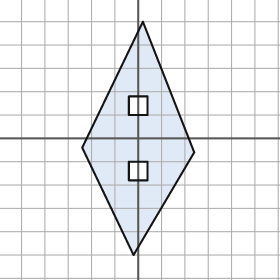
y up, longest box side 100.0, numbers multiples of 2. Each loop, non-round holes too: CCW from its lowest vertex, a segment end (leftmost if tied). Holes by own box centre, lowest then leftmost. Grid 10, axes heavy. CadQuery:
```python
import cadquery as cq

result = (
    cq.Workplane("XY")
    .moveTo(-2.0, -50.0)
    .lineTo(24.0, -6.0)
    .lineTo(2.0, 50.0)
    .lineTo(-24.0, -4.0)
    .close()
    .moveTo(-4.0, -18.0)
    .lineTo(4.0, -18.0)
    .lineTo(4.0, -10.0)
    .lineTo(-4.0, -10.0)
    .close()
    .moveTo(-4.0, 10.0)
    .lineTo(4.0, 10.0)
    .lineTo(4.0, 18.0)
    .lineTo(-4.0, 18.0)
    .close()
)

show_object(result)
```